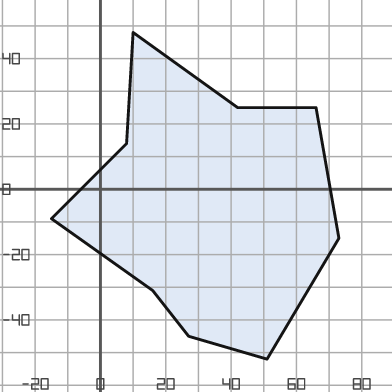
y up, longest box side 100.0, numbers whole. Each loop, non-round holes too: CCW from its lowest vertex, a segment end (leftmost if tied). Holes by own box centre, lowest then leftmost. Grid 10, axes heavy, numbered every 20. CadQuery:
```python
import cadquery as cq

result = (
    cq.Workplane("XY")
    .moveTo(51.0, -52.0)
    .lineTo(73.0, -15.0)
    .lineTo(66.0, 25.0)
    .lineTo(42.0, 25.0)
    .lineTo(10.0, 48.0)
    .lineTo(8.0, 14.0)
    .lineTo(-15.0, -9.0)
    .lineTo(16.0, -31.0)
    .lineTo(27.0, -45.0)
    .close()
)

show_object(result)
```